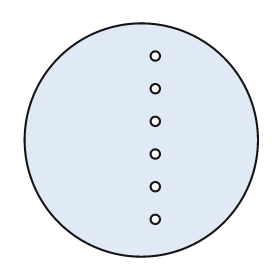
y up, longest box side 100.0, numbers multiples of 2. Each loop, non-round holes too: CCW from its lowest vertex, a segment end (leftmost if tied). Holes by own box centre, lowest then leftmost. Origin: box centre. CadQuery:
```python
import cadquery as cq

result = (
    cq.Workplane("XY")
    .moveTo(0.0, 0.0)
    .circle(50.0)
    .moveTo(6.0, -34.0)
    .circle(2.0)
    .moveTo(6.0, -20.0)
    .circle(2.0)
    .moveTo(6.0, -6.0)
    .circle(2.0)
    .moveTo(6.0, 8.0)
    .circle(2.0)
    .moveTo(6.0, 22.0)
    .circle(2.0)
    .moveTo(6.0, 36.0)
    .circle(2.0)
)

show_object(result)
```